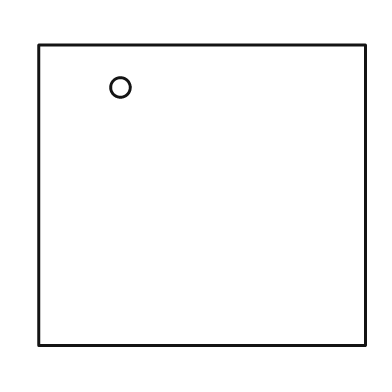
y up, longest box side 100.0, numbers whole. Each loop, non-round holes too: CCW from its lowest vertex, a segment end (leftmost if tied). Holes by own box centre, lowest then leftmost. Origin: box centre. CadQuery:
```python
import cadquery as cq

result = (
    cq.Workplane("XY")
    .moveTo(-50.0, -46.0)
    .lineTo(50.0, -46.0)
    .lineTo(50.0, 46.0)
    .lineTo(-50.0, 46.0)
    .close()
    .moveTo(-25.0, 33.0)
    .circle(3.0)
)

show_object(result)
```